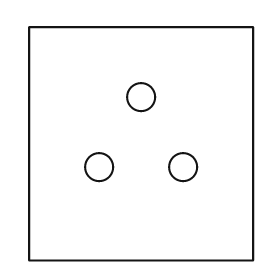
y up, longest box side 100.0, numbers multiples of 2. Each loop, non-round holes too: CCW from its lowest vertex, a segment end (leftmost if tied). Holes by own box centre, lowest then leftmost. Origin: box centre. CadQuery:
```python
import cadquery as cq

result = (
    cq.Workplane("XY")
    .moveTo(-48.0, -50.0)
    .lineTo(48.0, -50.0)
    .lineTo(48.0, 50.0)
    .lineTo(-48.0, 50.0)
    .close()
    .moveTo(-18.0, -10.0)
    .circle(6.0)
    .moveTo(18.0, -10.0)
    .circle(6.0)
    .moveTo(0.0, 20.0)
    .circle(6.0)
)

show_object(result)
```